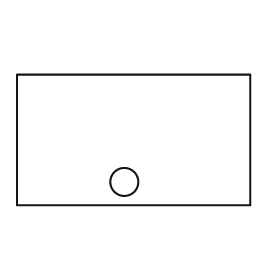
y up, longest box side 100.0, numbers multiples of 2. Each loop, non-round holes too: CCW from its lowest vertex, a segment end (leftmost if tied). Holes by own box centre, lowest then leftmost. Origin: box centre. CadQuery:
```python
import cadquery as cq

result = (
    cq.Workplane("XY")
    .moveTo(-50.0, -28.0)
    .lineTo(50.0, -28.0)
    .lineTo(50.0, 28.0)
    .lineTo(-50.0, 28.0)
    .close()
    .moveTo(-4.0, -18.0)
    .circle(6.0)
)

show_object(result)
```